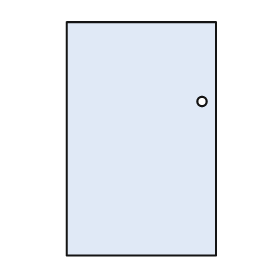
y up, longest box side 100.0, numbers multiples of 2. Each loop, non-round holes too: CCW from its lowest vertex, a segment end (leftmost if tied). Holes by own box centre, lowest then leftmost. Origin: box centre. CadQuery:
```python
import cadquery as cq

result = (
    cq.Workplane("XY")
    .moveTo(-32.0, -50.0)
    .lineTo(32.0, -50.0)
    .lineTo(32.0, 50.0)
    .lineTo(-32.0, 50.0)
    .close()
    .moveTo(26.0, 16.0)
    .circle(2.0)
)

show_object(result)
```